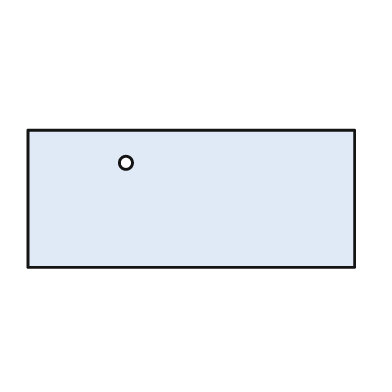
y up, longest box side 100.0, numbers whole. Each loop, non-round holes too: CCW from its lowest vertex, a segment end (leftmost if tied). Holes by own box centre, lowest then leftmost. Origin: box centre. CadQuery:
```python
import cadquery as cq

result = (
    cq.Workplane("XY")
    .moveTo(-50.0, -21.0)
    .lineTo(50.0, -21.0)
    .lineTo(50.0, 21.0)
    .lineTo(-50.0, 21.0)
    .close()
    .moveTo(-20.0, 11.0)
    .circle(2.0)
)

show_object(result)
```